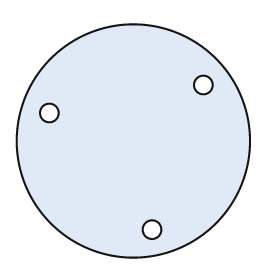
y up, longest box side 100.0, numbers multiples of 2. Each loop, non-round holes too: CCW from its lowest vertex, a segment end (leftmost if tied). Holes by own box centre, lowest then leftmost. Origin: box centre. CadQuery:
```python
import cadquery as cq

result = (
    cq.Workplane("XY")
    .moveTo(0.0, 0.0)
    .circle(50.0)
    .moveTo(8.0, -38.0)
    .circle(4.0)
    .moveTo(-36.0, 12.0)
    .circle(4.0)
    .moveTo(30.0, 24.0)
    .circle(4.0)
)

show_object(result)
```